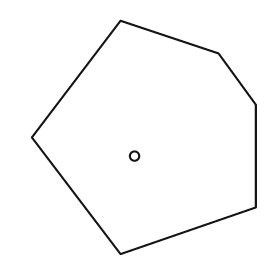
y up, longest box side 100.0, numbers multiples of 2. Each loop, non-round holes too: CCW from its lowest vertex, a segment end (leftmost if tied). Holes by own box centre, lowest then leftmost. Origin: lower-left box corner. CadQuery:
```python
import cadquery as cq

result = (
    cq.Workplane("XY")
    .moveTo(38.0, 0.0)
    .lineTo(96.0, 20.0)
    .lineTo(96.0, 64.0)
    .lineTo(80.0, 86.0)
    .lineTo(38.0, 100.0)
    .lineTo(0.0, 50.0)
    .close()
    .moveTo(44.0, 42.0)
    .circle(2.0)
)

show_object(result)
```